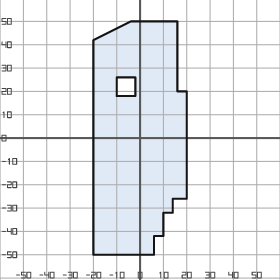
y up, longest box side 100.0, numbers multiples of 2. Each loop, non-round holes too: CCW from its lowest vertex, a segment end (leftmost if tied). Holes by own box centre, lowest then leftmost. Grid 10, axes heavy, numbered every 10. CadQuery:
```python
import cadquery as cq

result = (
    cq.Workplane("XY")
    .moveTo(-20.0, -50.0)
    .lineTo(6.0, -50.0)
    .lineTo(6.0, -42.0)
    .lineTo(10.0, -42.0)
    .lineTo(10.0, -32.0)
    .lineTo(14.0, -32.0)
    .lineTo(14.0, -26.0)
    .lineTo(20.0, -26.0)
    .lineTo(20.0, 20.0)
    .lineTo(16.0, 20.0)
    .lineTo(16.0, 50.0)
    .lineTo(-4.0, 50.0)
    .lineTo(-20.0, 42.0)
    .close()
    .moveTo(-10.0, 18.0)
    .lineTo(-2.0, 18.0)
    .lineTo(-2.0, 26.0)
    .lineTo(-10.0, 26.0)
    .close()
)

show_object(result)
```